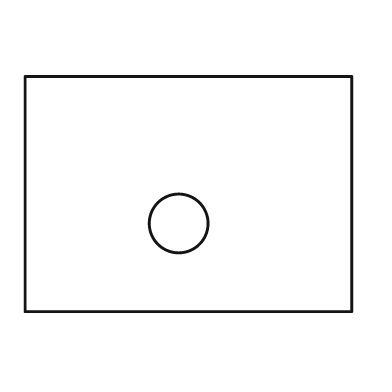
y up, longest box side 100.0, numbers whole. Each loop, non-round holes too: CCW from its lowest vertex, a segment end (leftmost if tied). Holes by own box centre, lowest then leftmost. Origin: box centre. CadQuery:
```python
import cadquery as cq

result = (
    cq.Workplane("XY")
    .moveTo(-50.0, -36.0)
    .lineTo(50.0, -36.0)
    .lineTo(50.0, 36.0)
    .lineTo(-50.0, 36.0)
    .close()
    .moveTo(-3.0, -9.0)
    .circle(9.0)
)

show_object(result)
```